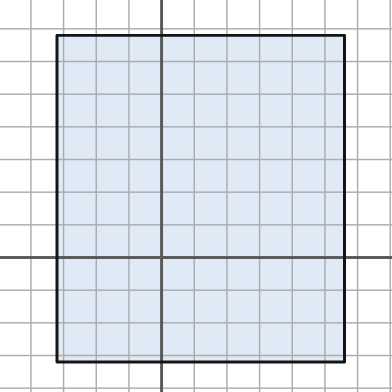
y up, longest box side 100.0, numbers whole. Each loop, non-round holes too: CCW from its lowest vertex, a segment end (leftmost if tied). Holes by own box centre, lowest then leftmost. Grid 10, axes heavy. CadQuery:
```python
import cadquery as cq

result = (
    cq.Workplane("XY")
    .moveTo(-32.0, -32.0)
    .lineTo(56.0, -32.0)
    .lineTo(56.0, 68.0)
    .lineTo(-32.0, 68.0)
    .close()
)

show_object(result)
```